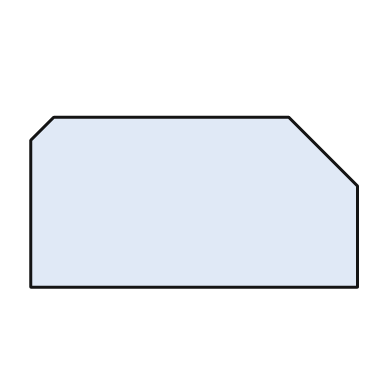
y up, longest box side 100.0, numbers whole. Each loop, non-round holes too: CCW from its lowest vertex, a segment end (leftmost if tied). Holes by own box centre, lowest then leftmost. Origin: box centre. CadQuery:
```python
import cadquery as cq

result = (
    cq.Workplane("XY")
    .moveTo(-50.0, -26.0)
    .lineTo(50.0, -26.0)
    .lineTo(50.0, 5.0)
    .lineTo(29.0, 26.0)
    .lineTo(-43.0, 26.0)
    .lineTo(-50.0, 19.0)
    .close()
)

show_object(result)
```